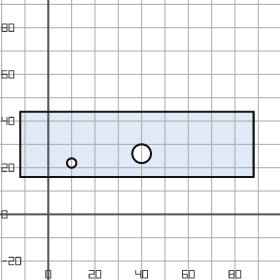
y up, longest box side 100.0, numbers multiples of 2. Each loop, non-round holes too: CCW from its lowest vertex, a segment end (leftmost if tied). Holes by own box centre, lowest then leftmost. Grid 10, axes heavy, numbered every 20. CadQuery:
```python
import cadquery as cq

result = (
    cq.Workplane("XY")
    .moveTo(-12.0, 16.0)
    .lineTo(88.0, 16.0)
    .lineTo(88.0, 44.0)
    .lineTo(-12.0, 44.0)
    .close()
    .moveTo(10.0, 22.0)
    .circle(2.0)
    .moveTo(40.0, 26.0)
    .circle(4.0)
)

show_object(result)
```